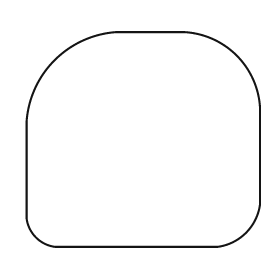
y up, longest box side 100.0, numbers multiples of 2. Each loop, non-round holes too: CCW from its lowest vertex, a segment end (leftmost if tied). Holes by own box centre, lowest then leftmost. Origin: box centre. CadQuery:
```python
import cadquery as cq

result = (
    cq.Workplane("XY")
    .moveTo(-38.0, -46.0)
    .lineTo(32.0, -46.0)
    .threePointArc((44.0, -40.0), (50.0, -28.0))
    .lineTo(50.0, 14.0)
    .threePointArc((40.0, 36.0), (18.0, 46.0))
    .lineTo(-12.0, 46.0)
    .threePointArc((-38.0, 34.0), (-50.0, 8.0))
    .lineTo(-50.0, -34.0)
    .threePointArc((-46.0, -42.0), (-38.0, -46.0))
    .close()
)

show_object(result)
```